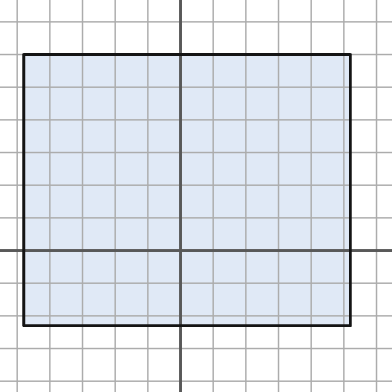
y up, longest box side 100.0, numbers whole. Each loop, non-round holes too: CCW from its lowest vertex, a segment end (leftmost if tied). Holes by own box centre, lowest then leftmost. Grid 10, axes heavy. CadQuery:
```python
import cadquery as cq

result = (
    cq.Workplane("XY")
    .moveTo(-48.0, -23.0)
    .lineTo(52.0, -23.0)
    .lineTo(52.0, 60.0)
    .lineTo(-48.0, 60.0)
    .close()
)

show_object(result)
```